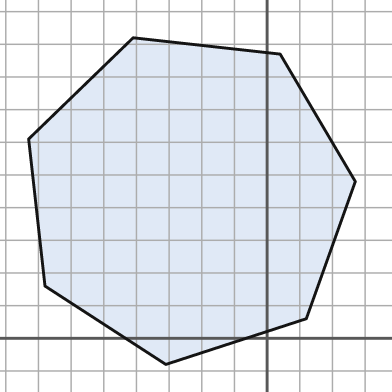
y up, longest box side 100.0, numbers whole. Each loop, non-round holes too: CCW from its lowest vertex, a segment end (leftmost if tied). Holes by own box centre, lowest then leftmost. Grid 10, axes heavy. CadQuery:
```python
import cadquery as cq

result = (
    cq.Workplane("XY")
    .moveTo(-31.0, -8.0)
    .lineTo(12.0, 6.0)
    .lineTo(27.0, 48.0)
    .lineTo(4.0, 87.0)
    .lineTo(-41.0, 92.0)
    .lineTo(-73.0, 61.0)
    .lineTo(-68.0, 16.0)
    .close()
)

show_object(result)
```